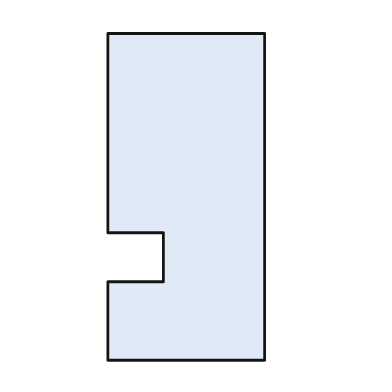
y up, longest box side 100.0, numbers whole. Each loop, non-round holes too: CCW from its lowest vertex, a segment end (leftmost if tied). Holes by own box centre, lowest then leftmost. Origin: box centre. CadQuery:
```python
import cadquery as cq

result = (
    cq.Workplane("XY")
    .moveTo(-24.0, -50.0)
    .lineTo(24.0, -50.0)
    .lineTo(24.0, 50.0)
    .lineTo(-24.0, 50.0)
    .lineTo(-24.0, -11.0)
    .lineTo(-7.0, -11.0)
    .lineTo(-7.0, -26.0)
    .lineTo(-24.0, -26.0)
    .close()
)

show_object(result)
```